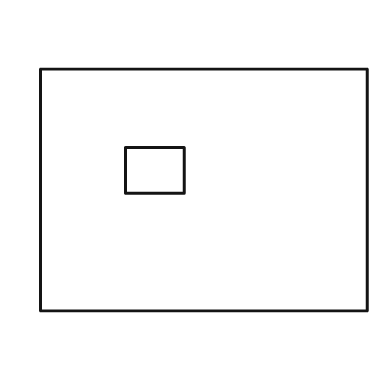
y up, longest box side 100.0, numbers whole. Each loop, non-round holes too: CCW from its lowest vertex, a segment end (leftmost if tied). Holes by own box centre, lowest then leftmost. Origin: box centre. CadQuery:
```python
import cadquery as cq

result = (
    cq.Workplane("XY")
    .moveTo(-50.0, -37.0)
    .lineTo(50.0, -37.0)
    .lineTo(50.0, 37.0)
    .lineTo(-50.0, 37.0)
    .close()
    .moveTo(-24.0, -1.0)
    .lineTo(-6.0, -1.0)
    .lineTo(-6.0, 13.0)
    .lineTo(-24.0, 13.0)
    .close()
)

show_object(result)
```